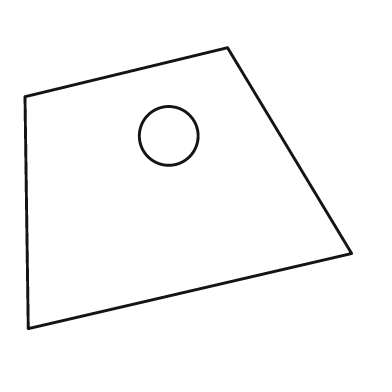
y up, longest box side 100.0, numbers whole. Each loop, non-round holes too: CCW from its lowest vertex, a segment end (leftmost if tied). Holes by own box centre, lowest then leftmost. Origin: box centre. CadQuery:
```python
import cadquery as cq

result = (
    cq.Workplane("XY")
    .moveTo(-49.0, -43.0)
    .lineTo(50.0, -20.0)
    .lineTo(12.0, 43.0)
    .lineTo(-50.0, 28.0)
    .close()
    .moveTo(-6.0, 16.0)
    .circle(9.0)
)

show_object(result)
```